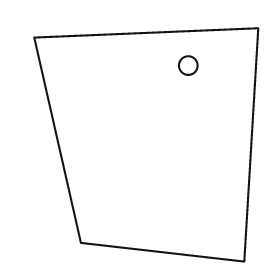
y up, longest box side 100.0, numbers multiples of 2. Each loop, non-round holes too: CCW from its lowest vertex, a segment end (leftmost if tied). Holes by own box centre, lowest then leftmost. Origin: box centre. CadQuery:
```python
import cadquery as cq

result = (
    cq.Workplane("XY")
    .moveTo(42.0, -50.0)
    .lineTo(48.0, 50.0)
    .lineTo(-48.0, 46.0)
    .lineTo(-28.0, -42.0)
    .close()
    .moveTo(18.0, 34.0)
    .circle(4.0)
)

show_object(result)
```